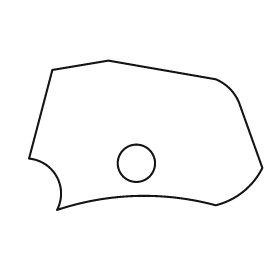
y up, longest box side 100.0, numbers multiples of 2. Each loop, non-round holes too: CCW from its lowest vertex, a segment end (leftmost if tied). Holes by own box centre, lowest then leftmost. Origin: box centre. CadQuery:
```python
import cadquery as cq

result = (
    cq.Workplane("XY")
    .moveTo(-38.0, -32.0)
    .threePointArc((-4.0, -26.0), (30.0, -30.0))
    .threePointArc((42.0, -24.0), (50.0, -14.0))
    .lineTo(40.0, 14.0)
    .threePointArc((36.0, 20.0), (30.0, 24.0))
    .lineTo(-16.0, 32.0)
    .lineTo(-40.0, 28.0)
    .lineTo(-50.0, -10.0)
    .threePointArc((-38.0, -18.0), (-38.0, -32.0))
    .close()
    .moveTo(-4.0, -12.0)
    .circle(8.0)
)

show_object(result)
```